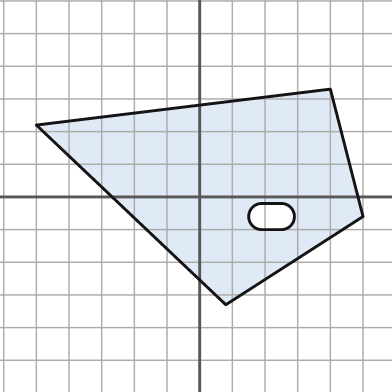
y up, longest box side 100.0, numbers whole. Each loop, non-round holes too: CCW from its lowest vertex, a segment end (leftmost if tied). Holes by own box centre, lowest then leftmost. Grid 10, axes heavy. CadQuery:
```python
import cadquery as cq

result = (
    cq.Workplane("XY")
    .moveTo(8.0, -33.0)
    .lineTo(50.0, -6.0)
    .lineTo(40.0, 33.0)
    .lineTo(-50.0, 22.0)
    .close()
    .moveTo(19.0, -10.0)
    .lineTo(25.0, -10.0)
    .threePointArc((29.0, -6.0), (25.0, -2.0))
    .lineTo(19.0, -2.0)
    .threePointArc((15.0, -6.0), (19.0, -10.0))
    .close()
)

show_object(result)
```